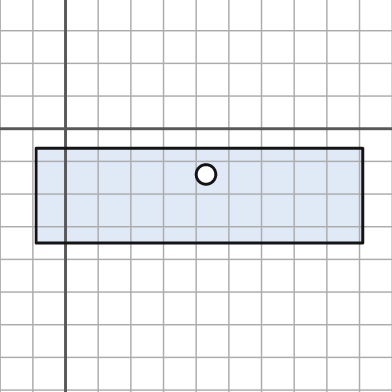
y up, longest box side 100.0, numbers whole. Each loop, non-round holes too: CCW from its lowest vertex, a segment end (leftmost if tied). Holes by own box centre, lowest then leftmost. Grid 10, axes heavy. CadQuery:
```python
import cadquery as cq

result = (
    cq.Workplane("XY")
    .moveTo(-9.0, -35.0)
    .lineTo(91.0, -35.0)
    .lineTo(91.0, -6.0)
    .lineTo(-9.0, -6.0)
    .close()
    .moveTo(43.0, -14.0)
    .circle(3.0)
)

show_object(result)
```